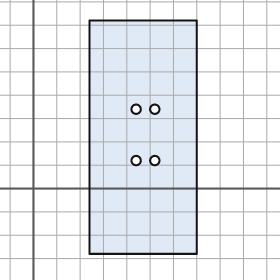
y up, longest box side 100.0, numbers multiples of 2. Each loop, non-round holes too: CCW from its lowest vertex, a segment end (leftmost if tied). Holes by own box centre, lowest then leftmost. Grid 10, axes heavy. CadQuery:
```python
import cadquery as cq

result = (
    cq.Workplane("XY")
    .moveTo(24.0, -28.0)
    .lineTo(70.0, -28.0)
    .lineTo(70.0, 72.0)
    .lineTo(24.0, 72.0)
    .close()
    .moveTo(44.0, 12.0)
    .circle(2.0)
    .moveTo(52.0, 12.0)
    .circle(2.0)
    .moveTo(44.0, 34.0)
    .circle(2.0)
    .moveTo(52.0, 34.0)
    .circle(2.0)
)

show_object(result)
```